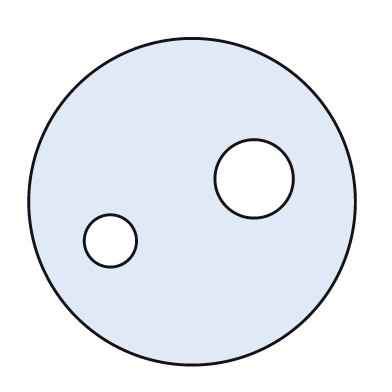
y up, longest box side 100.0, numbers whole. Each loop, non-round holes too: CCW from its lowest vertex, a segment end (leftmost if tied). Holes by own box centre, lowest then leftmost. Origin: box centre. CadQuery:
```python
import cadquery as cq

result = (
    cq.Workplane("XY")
    .moveTo(0.0, 0.0)
    .circle(50.0)
    .moveTo(-25.0, -12.0)
    .circle(8.0)
    .moveTo(19.0, 7.0)
    .circle(12.0)
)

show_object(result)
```